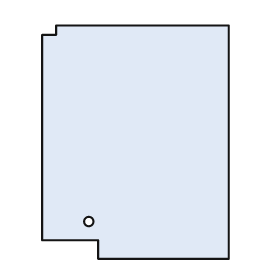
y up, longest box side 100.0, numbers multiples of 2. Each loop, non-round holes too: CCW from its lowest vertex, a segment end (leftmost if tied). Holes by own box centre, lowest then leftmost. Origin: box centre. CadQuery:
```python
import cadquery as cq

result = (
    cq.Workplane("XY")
    .moveTo(-16.0, -50.0)
    .lineTo(40.0, -50.0)
    .lineTo(40.0, 50.0)
    .lineTo(-34.0, 50.0)
    .lineTo(-34.0, 46.0)
    .lineTo(-40.0, 46.0)
    .lineTo(-40.0, -42.0)
    .lineTo(-16.0, -42.0)
    .close()
    .moveTo(-20.0, -34.0)
    .circle(2.0)
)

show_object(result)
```